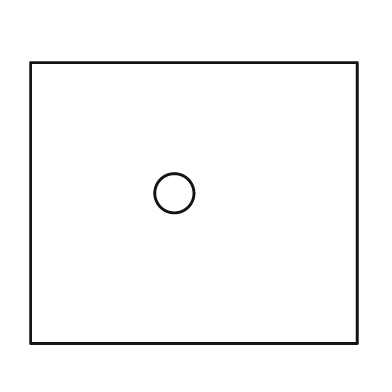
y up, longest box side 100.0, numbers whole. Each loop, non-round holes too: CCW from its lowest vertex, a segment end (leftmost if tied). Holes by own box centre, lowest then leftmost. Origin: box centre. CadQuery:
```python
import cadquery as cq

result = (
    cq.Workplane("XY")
    .moveTo(-50.0, -43.0)
    .lineTo(50.0, -43.0)
    .lineTo(50.0, 43.0)
    .lineTo(-50.0, 43.0)
    .close()
    .moveTo(-6.0, 3.0)
    .circle(6.0)
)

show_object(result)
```